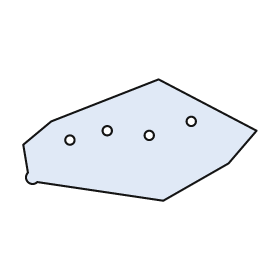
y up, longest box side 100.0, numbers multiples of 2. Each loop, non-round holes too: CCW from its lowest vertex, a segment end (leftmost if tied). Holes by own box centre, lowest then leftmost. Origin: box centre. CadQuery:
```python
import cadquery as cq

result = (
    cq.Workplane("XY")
    .moveTo(10.0, -26.0)
    .lineTo(38.0, -10.0)
    .lineTo(50.0, 4.0)
    .lineTo(8.0, 26.0)
    .lineTo(-38.0, 8.0)
    .lineTo(-50.0, -2.0)
    .lineTo(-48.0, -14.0)
    .threePointArc((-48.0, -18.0), (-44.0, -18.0))
    .close()
    .moveTo(-30.0, 0.0)
    .circle(2.0)
    .moveTo(4.0, 2.0)
    .circle(2.0)
    .moveTo(-14.0, 4.0)
    .circle(2.0)
    .moveTo(22.0, 8.0)
    .circle(2.0)
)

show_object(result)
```